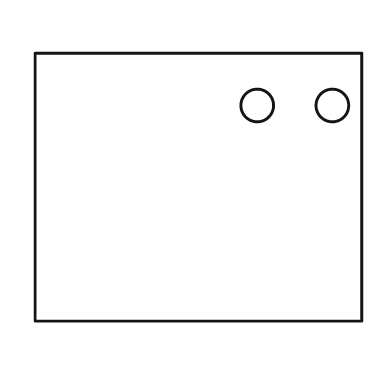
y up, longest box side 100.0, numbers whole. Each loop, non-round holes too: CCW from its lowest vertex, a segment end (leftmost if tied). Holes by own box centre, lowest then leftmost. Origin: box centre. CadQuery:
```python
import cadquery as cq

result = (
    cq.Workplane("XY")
    .moveTo(-50.0, -41.0)
    .lineTo(50.0, -41.0)
    .lineTo(50.0, 41.0)
    .lineTo(-50.0, 41.0)
    .close()
    .moveTo(18.0, 25.0)
    .circle(5.0)
    .moveTo(41.0, 25.0)
    .circle(5.0)
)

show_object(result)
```